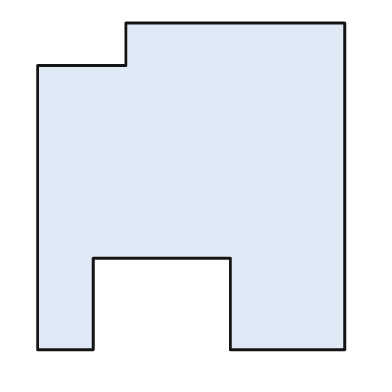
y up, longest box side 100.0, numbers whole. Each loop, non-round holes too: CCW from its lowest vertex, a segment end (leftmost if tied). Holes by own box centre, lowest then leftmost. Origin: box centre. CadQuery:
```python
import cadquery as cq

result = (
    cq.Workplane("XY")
    .moveTo(-47.0, -50.0)
    .lineTo(-30.0, -50.0)
    .lineTo(-30.0, -22.0)
    .lineTo(12.0, -22.0)
    .lineTo(12.0, -50.0)
    .lineTo(47.0, -50.0)
    .lineTo(47.0, 50.0)
    .lineTo(-20.0, 50.0)
    .lineTo(-20.0, 37.0)
    .lineTo(-47.0, 37.0)
    .close()
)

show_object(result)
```